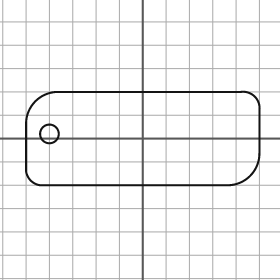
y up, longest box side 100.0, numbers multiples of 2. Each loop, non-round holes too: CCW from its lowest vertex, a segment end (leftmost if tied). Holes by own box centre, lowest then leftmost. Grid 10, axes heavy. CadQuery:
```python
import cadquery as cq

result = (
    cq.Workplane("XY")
    .moveTo(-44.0, -20.0)
    .lineTo(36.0, -20.0)
    .threePointArc((46.0, -16.0), (50.0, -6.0))
    .lineTo(50.0, 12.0)
    .threePointArc((48.0, 18.0), (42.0, 20.0))
    .lineTo(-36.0, 20.0)
    .threePointArc((-46.0, 16.0), (-50.0, 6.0))
    .lineTo(-50.0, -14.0)
    .threePointArc((-48.0, -18.0), (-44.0, -20.0))
    .close()
    .moveTo(-40.0, 2.0)
    .circle(4.0)
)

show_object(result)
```